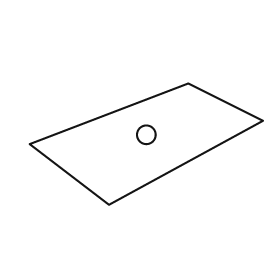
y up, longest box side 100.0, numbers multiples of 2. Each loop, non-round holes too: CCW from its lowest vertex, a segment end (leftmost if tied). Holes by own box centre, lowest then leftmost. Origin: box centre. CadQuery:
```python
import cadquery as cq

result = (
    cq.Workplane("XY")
    .moveTo(-16.0, -26.0)
    .lineTo(50.0, 10.0)
    .lineTo(18.0, 26.0)
    .lineTo(-50.0, 0.0)
    .close()
    .moveTo(0.0, 4.0)
    .circle(4.0)
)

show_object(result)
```